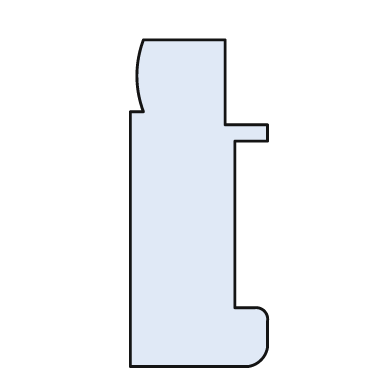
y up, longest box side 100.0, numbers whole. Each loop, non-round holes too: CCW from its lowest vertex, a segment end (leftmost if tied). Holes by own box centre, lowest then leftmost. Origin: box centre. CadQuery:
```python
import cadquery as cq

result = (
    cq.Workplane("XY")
    .moveTo(-21.0, -50.0)
    .lineTo(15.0, -50.0)
    .threePointArc((19.0, -48.0), (21.0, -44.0))
    .lineTo(21.0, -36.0)
    .threePointArc((20.0, -33.0), (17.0, -32.0))
    .lineTo(11.0, -32.0)
    .lineTo(11.0, 19.0)
    .lineTo(21.0, 19.0)
    .lineTo(21.0, 24.0)
    .lineTo(8.0, 24.0)
    .lineTo(8.0, 50.0)
    .lineTo(-17.0, 50.0)
    .threePointArc((-19.0, 39.0), (-17.0, 28.0))
    .lineTo(-21.0, 28.0)
    .close()
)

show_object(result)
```